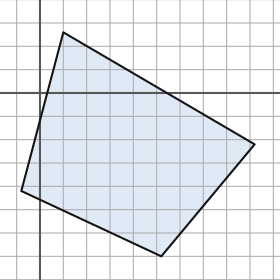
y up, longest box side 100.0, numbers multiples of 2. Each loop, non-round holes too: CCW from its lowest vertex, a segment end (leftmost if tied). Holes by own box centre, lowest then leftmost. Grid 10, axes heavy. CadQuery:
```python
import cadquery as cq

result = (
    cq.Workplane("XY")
    .moveTo(52.0, -70.0)
    .lineTo(92.0, -22.0)
    .lineTo(10.0, 26.0)
    .lineTo(-8.0, -42.0)
    .close()
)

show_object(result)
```